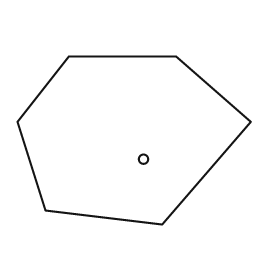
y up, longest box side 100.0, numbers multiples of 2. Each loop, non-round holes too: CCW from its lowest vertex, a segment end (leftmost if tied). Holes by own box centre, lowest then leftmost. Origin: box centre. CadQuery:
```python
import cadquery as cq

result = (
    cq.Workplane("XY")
    .moveTo(12.0, -36.0)
    .lineTo(50.0, 8.0)
    .lineTo(18.0, 36.0)
    .lineTo(-28.0, 36.0)
    .lineTo(-50.0, 8.0)
    .lineTo(-38.0, -30.0)
    .close()
    .moveTo(4.0, -8.0)
    .circle(2.0)
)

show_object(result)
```